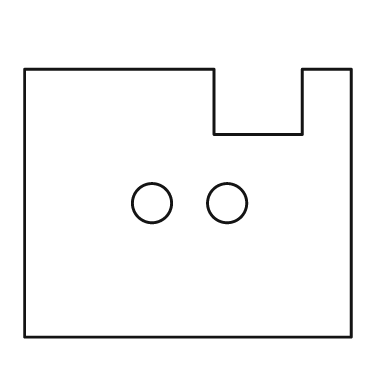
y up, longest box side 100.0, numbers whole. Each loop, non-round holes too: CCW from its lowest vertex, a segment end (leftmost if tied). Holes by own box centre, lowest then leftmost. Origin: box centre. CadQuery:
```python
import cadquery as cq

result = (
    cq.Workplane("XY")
    .moveTo(-50.0, -41.0)
    .lineTo(50.0, -41.0)
    .lineTo(50.0, 41.0)
    .lineTo(35.0, 41.0)
    .lineTo(35.0, 21.0)
    .lineTo(8.0, 21.0)
    .lineTo(8.0, 41.0)
    .lineTo(-50.0, 41.0)
    .close()
    .moveTo(-11.0, 0.0)
    .circle(6.0)
    .moveTo(12.0, 0.0)
    .circle(6.0)
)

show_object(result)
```